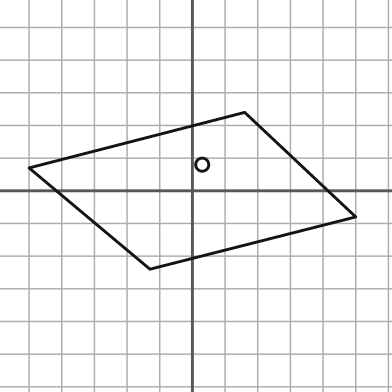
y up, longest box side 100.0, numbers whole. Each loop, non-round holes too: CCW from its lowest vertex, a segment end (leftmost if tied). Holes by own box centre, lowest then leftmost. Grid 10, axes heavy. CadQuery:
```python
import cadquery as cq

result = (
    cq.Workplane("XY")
    .moveTo(-13.0, -24.0)
    .lineTo(50.0, -8.0)
    .lineTo(16.0, 24.0)
    .lineTo(-50.0, 7.0)
    .close()
    .moveTo(3.0, 8.0)
    .circle(2.0)
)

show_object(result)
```